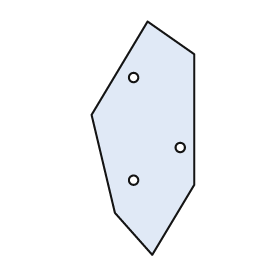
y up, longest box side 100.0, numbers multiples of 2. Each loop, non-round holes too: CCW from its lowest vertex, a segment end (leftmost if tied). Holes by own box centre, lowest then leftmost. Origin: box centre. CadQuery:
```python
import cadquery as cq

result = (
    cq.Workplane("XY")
    .moveTo(4.0, -50.0)
    .lineTo(22.0, -20.0)
    .lineTo(22.0, 36.0)
    .lineTo(2.0, 50.0)
    .lineTo(-22.0, 10.0)
    .lineTo(-12.0, -32.0)
    .close()
    .moveTo(-4.0, -18.0)
    .circle(2.0)
    .moveTo(16.0, -4.0)
    .circle(2.0)
    .moveTo(-4.0, 26.0)
    .circle(2.0)
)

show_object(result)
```